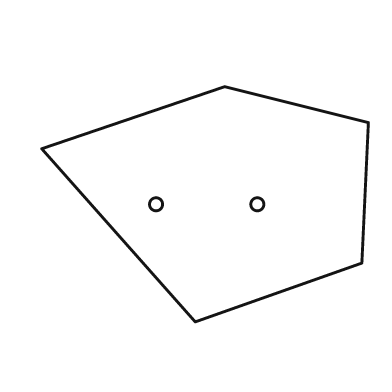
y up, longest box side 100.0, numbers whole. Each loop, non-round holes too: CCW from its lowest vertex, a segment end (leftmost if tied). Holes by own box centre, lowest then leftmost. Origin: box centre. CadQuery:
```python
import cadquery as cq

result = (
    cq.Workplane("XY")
    .moveTo(-3.0, -36.0)
    .lineTo(48.0, -18.0)
    .lineTo(50.0, 25.0)
    .lineTo(6.0, 36.0)
    .lineTo(-50.0, 17.0)
    .close()
    .moveTo(-15.0, 0.0)
    .circle(2.0)
    .moveTo(16.0, 0.0)
    .circle(2.0)
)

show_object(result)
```